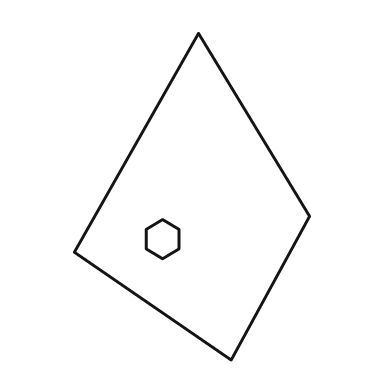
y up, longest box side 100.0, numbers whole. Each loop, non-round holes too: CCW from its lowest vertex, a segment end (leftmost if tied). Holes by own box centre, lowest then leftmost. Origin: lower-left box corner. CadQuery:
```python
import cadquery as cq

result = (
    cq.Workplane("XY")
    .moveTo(48.0, 0.0)
    .lineTo(72.0, 44.0)
    .lineTo(38.0, 100.0)
    .lineTo(0.0, 33.0)
    .close()
    .moveTo(27.0, 31.0)
    .lineTo(32.0, 34.0)
    .lineTo(32.0, 40.0)
    .lineTo(27.0, 43.0)
    .lineTo(22.0, 40.0)
    .lineTo(22.0, 34.0)
    .close()
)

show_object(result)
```